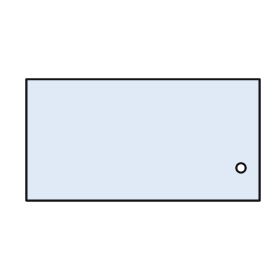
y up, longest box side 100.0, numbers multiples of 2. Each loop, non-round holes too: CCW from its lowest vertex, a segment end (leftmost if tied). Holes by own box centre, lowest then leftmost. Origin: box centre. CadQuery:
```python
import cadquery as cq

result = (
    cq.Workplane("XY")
    .moveTo(-50.0, -26.0)
    .lineTo(50.0, -26.0)
    .lineTo(50.0, 26.0)
    .lineTo(-50.0, 26.0)
    .close()
    .moveTo(42.0, -12.0)
    .circle(2.0)
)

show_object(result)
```